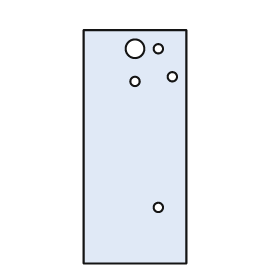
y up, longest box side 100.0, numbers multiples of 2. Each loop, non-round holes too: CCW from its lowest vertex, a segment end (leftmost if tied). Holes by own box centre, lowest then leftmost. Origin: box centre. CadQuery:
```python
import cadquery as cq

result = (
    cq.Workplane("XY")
    .moveTo(-22.0, -50.0)
    .lineTo(22.0, -50.0)
    .lineTo(22.0, 50.0)
    .lineTo(-22.0, 50.0)
    .close()
    .moveTo(10.0, -26.0)
    .circle(2.0)
    .moveTo(0.0, 28.0)
    .circle(2.0)
    .moveTo(16.0, 30.0)
    .circle(2.0)
    .moveTo(0.0, 42.0)
    .circle(4.0)
    .moveTo(10.0, 42.0)
    .circle(2.0)
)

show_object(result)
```